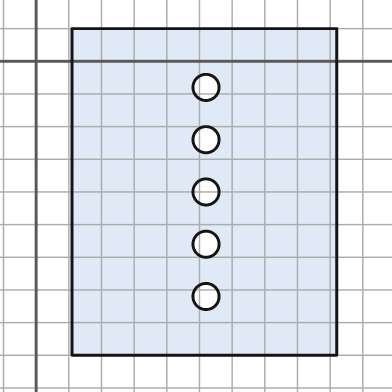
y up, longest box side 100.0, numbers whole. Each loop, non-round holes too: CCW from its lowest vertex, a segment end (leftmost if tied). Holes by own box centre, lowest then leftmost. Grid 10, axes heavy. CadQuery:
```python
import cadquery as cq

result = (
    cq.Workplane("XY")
    .moveTo(11.0, -90.0)
    .lineTo(92.0, -90.0)
    .lineTo(92.0, 10.0)
    .lineTo(11.0, 10.0)
    .close()
    .moveTo(52.0, -72.0)
    .circle(4.0)
    .moveTo(52.0, -56.0)
    .circle(4.0)
    .moveTo(52.0, -40.0)
    .circle(4.0)
    .moveTo(52.0, -24.0)
    .circle(4.0)
    .moveTo(52.0, -8.0)
    .circle(4.0)
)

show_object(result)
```